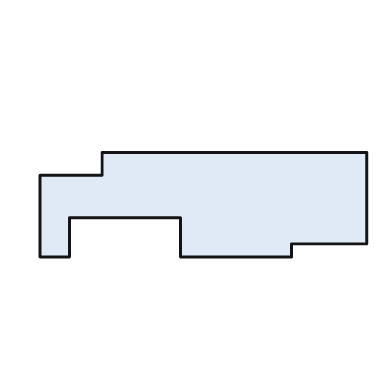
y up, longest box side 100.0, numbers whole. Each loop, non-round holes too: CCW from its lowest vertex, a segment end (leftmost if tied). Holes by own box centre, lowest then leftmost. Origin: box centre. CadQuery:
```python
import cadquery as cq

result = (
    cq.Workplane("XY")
    .moveTo(-50.0, -16.0)
    .lineTo(-41.0, -16.0)
    .lineTo(-41.0, -4.0)
    .lineTo(-7.0, -4.0)
    .lineTo(-7.0, -16.0)
    .lineTo(27.0, -16.0)
    .lineTo(27.0, -12.0)
    .lineTo(50.0, -12.0)
    .lineTo(50.0, 16.0)
    .lineTo(-31.0, 16.0)
    .lineTo(-31.0, 9.0)
    .lineTo(-50.0, 9.0)
    .close()
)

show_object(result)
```